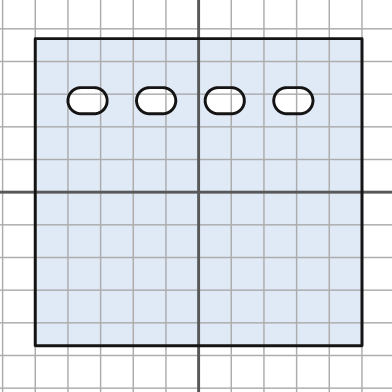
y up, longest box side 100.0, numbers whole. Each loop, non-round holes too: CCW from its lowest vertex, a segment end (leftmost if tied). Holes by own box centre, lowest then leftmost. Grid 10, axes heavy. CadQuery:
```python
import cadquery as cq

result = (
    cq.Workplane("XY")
    .moveTo(-50.0, -47.0)
    .lineTo(50.0, -47.0)
    .lineTo(50.0, 47.0)
    .lineTo(-50.0, 47.0)
    .close()
    .moveTo(-36.0, 24.0)
    .lineTo(-32.0, 24.0)
    .threePointArc((-28.0, 28.0), (-32.0, 32.0))
    .lineTo(-36.0, 32.0)
    .threePointArc((-40.0, 28.0), (-36.0, 24.0))
    .close()
    .moveTo(-15.0, 24.0)
    .lineTo(-11.0, 24.0)
    .threePointArc((-7.0, 28.0), (-11.0, 32.0))
    .lineTo(-15.0, 32.0)
    .threePointArc((-19.0, 28.0), (-15.0, 24.0))
    .close()
    .moveTo(6.0, 24.0)
    .lineTo(10.0, 24.0)
    .threePointArc((14.0, 28.0), (10.0, 32.0))
    .lineTo(6.0, 32.0)
    .threePointArc((2.0, 28.0), (6.0, 24.0))
    .close()
    .moveTo(27.0, 24.0)
    .lineTo(31.0, 24.0)
    .threePointArc((35.0, 28.0), (31.0, 32.0))
    .lineTo(27.0, 32.0)
    .threePointArc((23.0, 28.0), (27.0, 24.0))
    .close()
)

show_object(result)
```